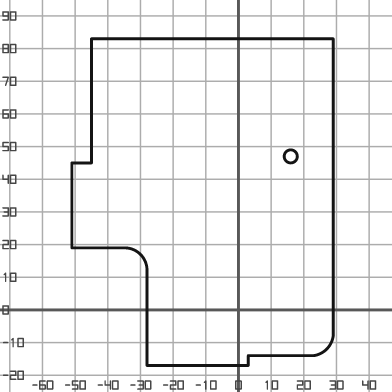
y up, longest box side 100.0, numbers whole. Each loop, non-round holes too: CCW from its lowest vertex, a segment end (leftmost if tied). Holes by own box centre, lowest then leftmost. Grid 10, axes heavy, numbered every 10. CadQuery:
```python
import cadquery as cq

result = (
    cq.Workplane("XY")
    .moveTo(-28.0, -17.0)
    .lineTo(3.0, -17.0)
    .lineTo(3.0, -14.0)
    .lineTo(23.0, -14.0)
    .threePointArc((27.0, -12.0), (29.0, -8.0))
    .lineTo(29.0, 83.0)
    .lineTo(-45.0, 83.0)
    .lineTo(-45.0, 45.0)
    .lineTo(-51.0, 45.0)
    .lineTo(-51.0, 19.0)
    .lineTo(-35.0, 19.0)
    .threePointArc((-30.0, 17.0), (-28.0, 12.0))
    .close()
    .moveTo(16.0, 47.0)
    .circle(2.0)
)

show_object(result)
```